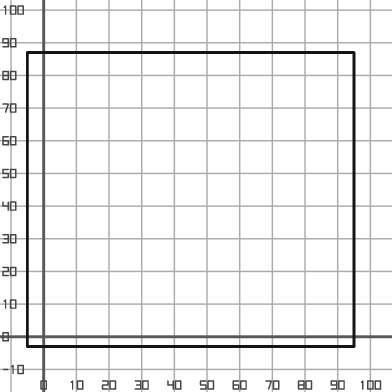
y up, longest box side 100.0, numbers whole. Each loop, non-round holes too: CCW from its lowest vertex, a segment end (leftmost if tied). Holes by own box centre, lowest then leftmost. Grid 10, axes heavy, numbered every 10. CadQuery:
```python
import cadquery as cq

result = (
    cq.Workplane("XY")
    .moveTo(-5.0, -3.0)
    .lineTo(95.0, -3.0)
    .lineTo(95.0, 87.0)
    .lineTo(-5.0, 87.0)
    .close()
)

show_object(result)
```